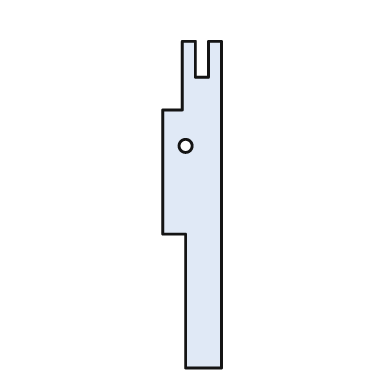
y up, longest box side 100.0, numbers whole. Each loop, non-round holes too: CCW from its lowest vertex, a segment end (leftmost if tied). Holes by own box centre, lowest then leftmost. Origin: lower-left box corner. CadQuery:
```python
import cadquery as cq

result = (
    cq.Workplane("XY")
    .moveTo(7.0, 0.0)
    .lineTo(18.0, 0.0)
    .lineTo(18.0, 100.0)
    .lineTo(14.0, 100.0)
    .lineTo(14.0, 89.0)
    .lineTo(10.0, 89.0)
    .lineTo(10.0, 100.0)
    .lineTo(6.0, 100.0)
    .lineTo(6.0, 79.0)
    .lineTo(0.0, 79.0)
    .lineTo(0.0, 41.0)
    .lineTo(7.0, 41.0)
    .close()
    .moveTo(7.0, 68.0)
    .circle(2.0)
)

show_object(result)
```